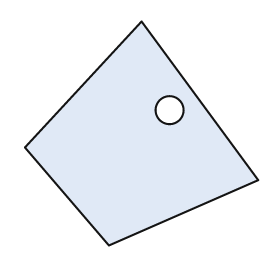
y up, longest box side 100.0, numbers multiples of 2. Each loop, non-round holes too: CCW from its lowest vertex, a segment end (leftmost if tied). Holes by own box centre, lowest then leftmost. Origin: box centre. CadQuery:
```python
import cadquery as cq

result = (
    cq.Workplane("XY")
    .moveTo(-14.0, -48.0)
    .lineTo(50.0, -20.0)
    .lineTo(0.0, 48.0)
    .lineTo(-50.0, -6.0)
    .close()
    .moveTo(12.0, 10.0)
    .circle(6.0)
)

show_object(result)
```